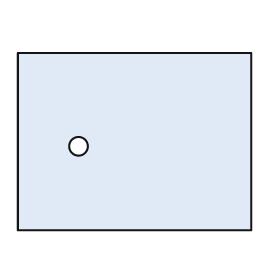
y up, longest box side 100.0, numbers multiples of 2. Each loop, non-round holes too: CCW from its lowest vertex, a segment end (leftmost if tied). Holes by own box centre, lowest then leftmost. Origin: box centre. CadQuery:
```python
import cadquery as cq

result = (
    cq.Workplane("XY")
    .moveTo(-50.0, -38.0)
    .lineTo(50.0, -38.0)
    .lineTo(50.0, 38.0)
    .lineTo(-50.0, 38.0)
    .close()
    .moveTo(-24.0, -2.0)
    .circle(4.0)
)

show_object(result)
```